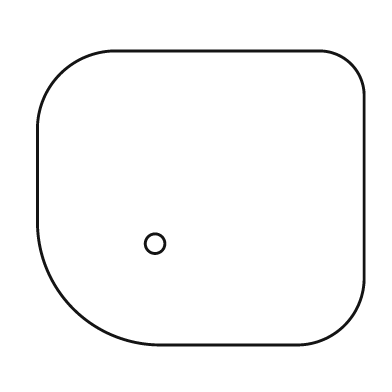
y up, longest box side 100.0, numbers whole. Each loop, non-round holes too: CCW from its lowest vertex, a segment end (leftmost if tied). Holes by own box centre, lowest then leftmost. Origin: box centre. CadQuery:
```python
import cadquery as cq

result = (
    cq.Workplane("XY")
    .moveTo(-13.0, -45.0)
    .lineTo(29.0, -45.0)
    .threePointArc((44.0, -39.0), (50.0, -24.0))
    .lineTo(50.0, 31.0)
    .threePointArc((46.0, 41.0), (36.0, 45.0))
    .lineTo(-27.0, 45.0)
    .threePointArc((-43.0, 38.0), (-50.0, 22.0))
    .lineTo(-50.0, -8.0)
    .threePointArc((-39.0, -34.0), (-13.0, -45.0))
    .close()
    .moveTo(-14.0, -14.0)
    .circle(3.0)
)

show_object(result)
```